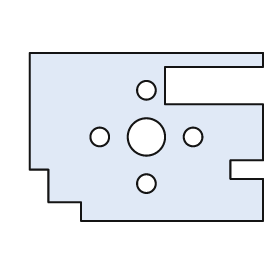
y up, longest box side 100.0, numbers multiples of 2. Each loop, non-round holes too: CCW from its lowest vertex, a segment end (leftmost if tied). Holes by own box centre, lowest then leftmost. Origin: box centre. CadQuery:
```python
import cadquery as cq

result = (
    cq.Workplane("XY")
    .moveTo(-28.0, -36.0)
    .lineTo(50.0, -36.0)
    .lineTo(50.0, -18.0)
    .lineTo(36.0, -18.0)
    .lineTo(36.0, -10.0)
    .lineTo(50.0, -10.0)
    .lineTo(50.0, 14.0)
    .lineTo(8.0, 14.0)
    .lineTo(8.0, 30.0)
    .lineTo(50.0, 30.0)
    .lineTo(50.0, 36.0)
    .lineTo(-50.0, 36.0)
    .lineTo(-50.0, -14.0)
    .lineTo(-42.0, -14.0)
    .lineTo(-42.0, -28.0)
    .lineTo(-28.0, -28.0)
    .close()
    .moveTo(0.0, -20.0)
    .circle(4.0)
    .moveTo(-20.0, 0.0)
    .circle(4.0)
    .moveTo(0.0, 0.0)
    .circle(8.0)
    .moveTo(20.0, 0.0)
    .circle(4.0)
    .moveTo(0.0, 20.0)
    .circle(4.0)
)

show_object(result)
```